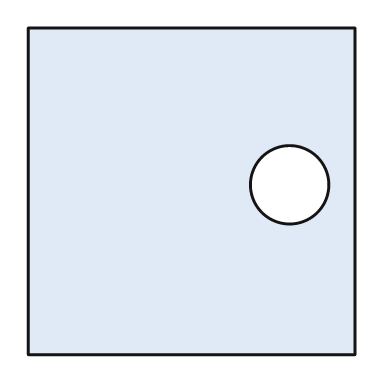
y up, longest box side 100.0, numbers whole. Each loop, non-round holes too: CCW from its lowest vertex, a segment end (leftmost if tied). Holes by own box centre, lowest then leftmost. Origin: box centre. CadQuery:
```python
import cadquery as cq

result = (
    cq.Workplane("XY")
    .moveTo(-50.0, -50.0)
    .lineTo(50.0, -50.0)
    .lineTo(50.0, 50.0)
    .lineTo(-50.0, 50.0)
    .close()
    .moveTo(30.0, 2.0)
    .circle(12.0)
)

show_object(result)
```